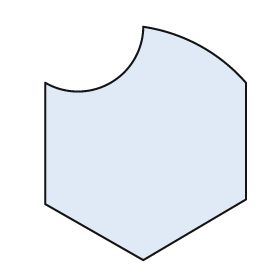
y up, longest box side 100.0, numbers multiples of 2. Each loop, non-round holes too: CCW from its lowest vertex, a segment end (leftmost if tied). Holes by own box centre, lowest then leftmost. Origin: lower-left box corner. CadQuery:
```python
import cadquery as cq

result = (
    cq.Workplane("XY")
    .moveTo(42.0, 0.0)
    .lineTo(86.0, 26.0)
    .lineTo(86.0, 76.0)
    .threePointArc((66.0, 92.0), (42.0, 100.0))
    .threePointArc((28.0, 76.0), (0.0, 76.0))
    .lineTo(0.0, 24.0)
    .close()
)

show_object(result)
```